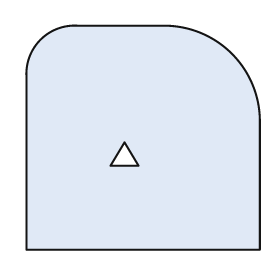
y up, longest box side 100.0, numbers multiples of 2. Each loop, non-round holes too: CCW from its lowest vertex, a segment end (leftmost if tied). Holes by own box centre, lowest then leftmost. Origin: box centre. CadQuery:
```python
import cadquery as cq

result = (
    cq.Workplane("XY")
    .moveTo(-50.0, -48.0)
    .lineTo(50.0, -48.0)
    .lineTo(50.0, 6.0)
    .threePointArc((38.0, 36.0), (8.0, 48.0))
    .lineTo(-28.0, 48.0)
    .threePointArc((-44.0, 42.0), (-50.0, 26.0))
    .close()
    .moveTo(-14.0, -12.0)
    .lineTo(-2.0, -12.0)
    .lineTo(-8.0, -2.0)
    .close()
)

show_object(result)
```